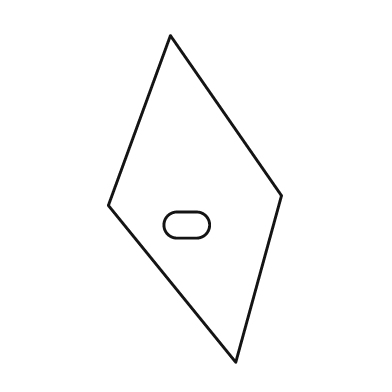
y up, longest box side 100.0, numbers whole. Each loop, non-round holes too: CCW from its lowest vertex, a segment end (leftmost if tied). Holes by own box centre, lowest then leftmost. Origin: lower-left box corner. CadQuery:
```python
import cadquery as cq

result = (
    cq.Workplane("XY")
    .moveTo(39.0, 0.0)
    .lineTo(53.0, 51.0)
    .lineTo(19.0, 100.0)
    .lineTo(0.0, 48.0)
    .close()
    .moveTo(21.0, 38.0)
    .lineTo(27.0, 38.0)
    .threePointArc((31.0, 42.0), (27.0, 46.0))
    .lineTo(21.0, 46.0)
    .threePointArc((17.0, 42.0), (21.0, 38.0))
    .close()
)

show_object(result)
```